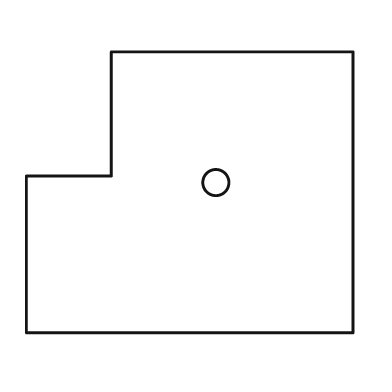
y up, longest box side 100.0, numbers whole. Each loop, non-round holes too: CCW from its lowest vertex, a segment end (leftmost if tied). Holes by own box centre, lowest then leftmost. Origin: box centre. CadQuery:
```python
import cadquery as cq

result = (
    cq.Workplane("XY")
    .moveTo(-50.0, -43.0)
    .lineTo(50.0, -43.0)
    .lineTo(50.0, 43.0)
    .lineTo(-24.0, 43.0)
    .lineTo(-24.0, 5.0)
    .lineTo(-50.0, 5.0)
    .close()
    .moveTo(8.0, 3.0)
    .circle(4.0)
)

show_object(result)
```